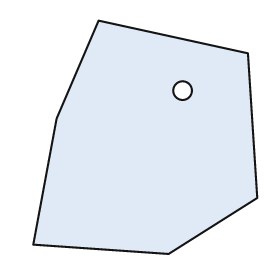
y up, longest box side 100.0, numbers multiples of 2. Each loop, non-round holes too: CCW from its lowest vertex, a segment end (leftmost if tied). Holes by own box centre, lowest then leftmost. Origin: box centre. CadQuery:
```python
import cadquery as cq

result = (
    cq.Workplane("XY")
    .moveTo(10.0, -50.0)
    .lineTo(48.0, -26.0)
    .lineTo(44.0, 36.0)
    .lineTo(-20.0, 50.0)
    .lineTo(-38.0, 8.0)
    .lineTo(-48.0, -46.0)
    .close()
    .moveTo(16.0, 20.0)
    .circle(4.0)
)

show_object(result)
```